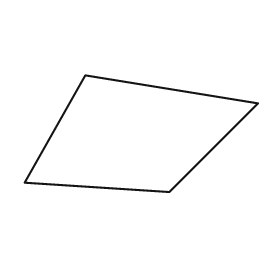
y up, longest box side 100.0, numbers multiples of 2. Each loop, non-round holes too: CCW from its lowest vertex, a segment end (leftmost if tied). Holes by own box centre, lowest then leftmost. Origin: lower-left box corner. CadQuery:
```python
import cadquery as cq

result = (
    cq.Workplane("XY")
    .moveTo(62.0, 0.0)
    .lineTo(100.0, 38.0)
    .lineTo(26.0, 50.0)
    .lineTo(0.0, 4.0)
    .close()
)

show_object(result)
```